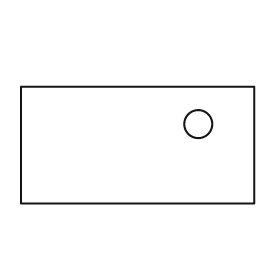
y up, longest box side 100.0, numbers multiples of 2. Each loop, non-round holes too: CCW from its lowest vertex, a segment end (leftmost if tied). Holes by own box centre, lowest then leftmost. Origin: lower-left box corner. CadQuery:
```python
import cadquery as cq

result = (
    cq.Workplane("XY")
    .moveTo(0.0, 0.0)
    .lineTo(100.0, 0.0)
    .lineTo(100.0, 50.0)
    .lineTo(0.0, 50.0)
    .close()
    .moveTo(76.0, 34.0)
    .circle(6.0)
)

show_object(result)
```